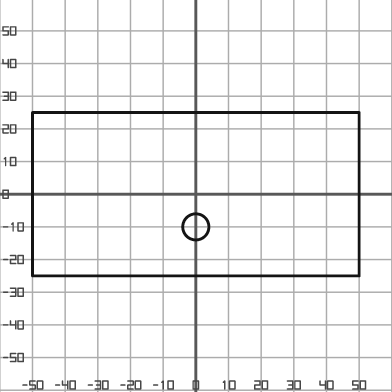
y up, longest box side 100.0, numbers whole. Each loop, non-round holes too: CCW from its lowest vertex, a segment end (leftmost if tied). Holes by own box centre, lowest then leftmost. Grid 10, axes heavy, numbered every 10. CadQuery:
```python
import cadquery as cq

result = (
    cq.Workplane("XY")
    .moveTo(-50.0, -25.0)
    .lineTo(50.0, -25.0)
    .lineTo(50.0, 25.0)
    .lineTo(-50.0, 25.0)
    .close()
    .moveTo(0.0, -10.0)
    .circle(4.0)
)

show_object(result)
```